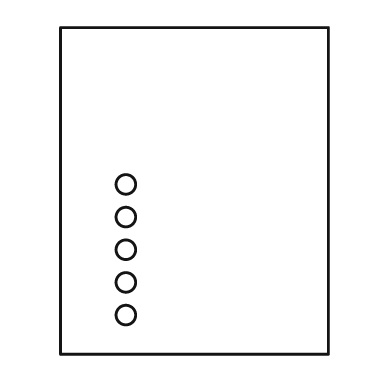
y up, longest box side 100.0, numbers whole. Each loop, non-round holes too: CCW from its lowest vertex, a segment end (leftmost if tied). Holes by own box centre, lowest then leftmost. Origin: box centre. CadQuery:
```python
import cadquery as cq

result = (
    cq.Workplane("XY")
    .moveTo(-41.0, -50.0)
    .lineTo(41.0, -50.0)
    .lineTo(41.0, 50.0)
    .lineTo(-41.0, 50.0)
    .close()
    .moveTo(-21.0, -38.0)
    .circle(3.0)
    .moveTo(-21.0, -28.0)
    .circle(3.0)
    .moveTo(-21.0, -18.0)
    .circle(3.0)
    .moveTo(-21.0, -8.0)
    .circle(3.0)
    .moveTo(-21.0, 2.0)
    .circle(3.0)
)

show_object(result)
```